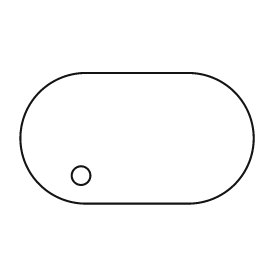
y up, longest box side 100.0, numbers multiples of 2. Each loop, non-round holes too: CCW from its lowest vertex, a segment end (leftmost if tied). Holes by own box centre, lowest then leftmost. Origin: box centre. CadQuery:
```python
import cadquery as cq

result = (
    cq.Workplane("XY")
    .moveTo(-22.0, -28.0)
    .lineTo(22.0, -28.0)
    .threePointArc((50.0, 0.0), (22.0, 28.0))
    .lineTo(-22.0, 28.0)
    .threePointArc((-50.0, 0.0), (-22.0, -28.0))
    .close()
    .moveTo(-24.0, -16.0)
    .circle(4.0)
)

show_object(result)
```